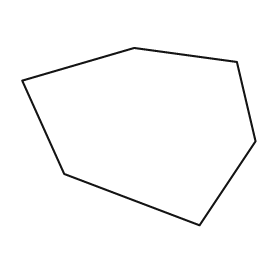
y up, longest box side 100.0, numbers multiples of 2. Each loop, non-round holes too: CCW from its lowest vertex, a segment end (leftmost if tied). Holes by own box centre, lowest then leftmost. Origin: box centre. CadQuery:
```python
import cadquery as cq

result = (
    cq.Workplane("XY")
    .moveTo(26.0, -38.0)
    .lineTo(50.0, -2.0)
    .lineTo(42.0, 32.0)
    .lineTo(-2.0, 38.0)
    .lineTo(-50.0, 24.0)
    .lineTo(-32.0, -16.0)
    .close()
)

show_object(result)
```